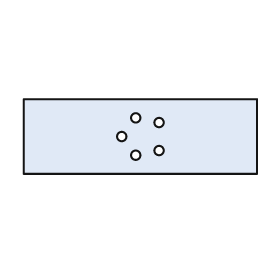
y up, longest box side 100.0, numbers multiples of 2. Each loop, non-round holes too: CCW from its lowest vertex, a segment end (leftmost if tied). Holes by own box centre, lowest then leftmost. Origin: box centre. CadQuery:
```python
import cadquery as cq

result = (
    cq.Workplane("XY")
    .moveTo(-50.0, -16.0)
    .lineTo(50.0, -16.0)
    .lineTo(50.0, 16.0)
    .lineTo(-50.0, 16.0)
    .close()
    .moveTo(-2.0, -8.0)
    .circle(2.0)
    .moveTo(8.0, -6.0)
    .circle(2.0)
    .moveTo(-8.0, 0.0)
    .circle(2.0)
    .moveTo(8.0, 6.0)
    .circle(2.0)
    .moveTo(-2.0, 8.0)
    .circle(2.0)
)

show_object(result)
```